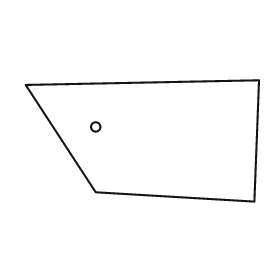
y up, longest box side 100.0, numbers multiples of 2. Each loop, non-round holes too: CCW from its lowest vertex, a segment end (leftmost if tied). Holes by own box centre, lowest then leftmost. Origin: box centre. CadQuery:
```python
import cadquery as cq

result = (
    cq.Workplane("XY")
    .moveTo(48.0, -26.0)
    .lineTo(50.0, 26.0)
    .lineTo(-50.0, 24.0)
    .lineTo(-20.0, -22.0)
    .close()
    .moveTo(-20.0, 6.0)
    .circle(2.0)
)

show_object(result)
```